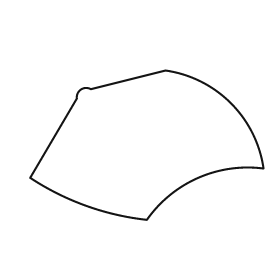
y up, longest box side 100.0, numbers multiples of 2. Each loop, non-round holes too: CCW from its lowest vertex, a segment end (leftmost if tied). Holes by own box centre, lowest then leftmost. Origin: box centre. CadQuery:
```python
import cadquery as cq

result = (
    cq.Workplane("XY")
    .moveTo(0.0, -32.0)
    .threePointArc((22.0, -14.0), (50.0, -10.0))
    .threePointArc((36.0, 18.0), (8.0, 32.0))
    .lineTo(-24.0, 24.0)
    .threePointArc((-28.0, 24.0), (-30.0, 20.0))
    .lineTo(-50.0, -14.0)
    .threePointArc((-26.0, -26.0), (0.0, -32.0))
    .close()
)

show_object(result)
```